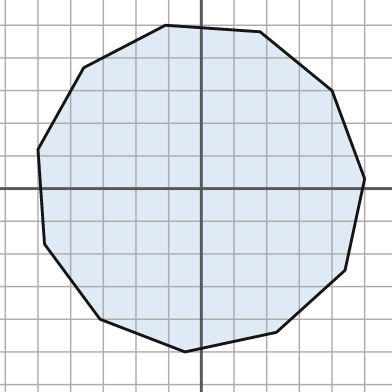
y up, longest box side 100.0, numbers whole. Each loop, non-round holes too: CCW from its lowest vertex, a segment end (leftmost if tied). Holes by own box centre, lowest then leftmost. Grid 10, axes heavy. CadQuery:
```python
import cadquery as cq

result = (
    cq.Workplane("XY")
    .moveTo(-5.0, -50.0)
    .lineTo(23.0, -44.0)
    .lineTo(44.0, -25.0)
    .lineTo(50.0, 3.0)
    .lineTo(40.0, 30.0)
    .lineTo(18.0, 48.0)
    .lineTo(-11.0, 50.0)
    .lineTo(-36.0, 37.0)
    .lineTo(-50.0, 12.0)
    .lineTo(-48.0, -17.0)
    .lineTo(-31.0, -40.0)
    .close()
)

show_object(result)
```